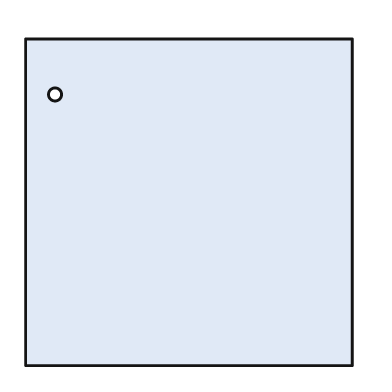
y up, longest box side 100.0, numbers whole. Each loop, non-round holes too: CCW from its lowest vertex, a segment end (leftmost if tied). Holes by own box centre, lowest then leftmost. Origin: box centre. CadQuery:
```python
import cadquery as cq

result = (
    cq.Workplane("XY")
    .moveTo(-50.0, -50.0)
    .lineTo(50.0, -50.0)
    .lineTo(50.0, 50.0)
    .lineTo(-50.0, 50.0)
    .close()
    .moveTo(-41.0, 33.0)
    .circle(2.0)
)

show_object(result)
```